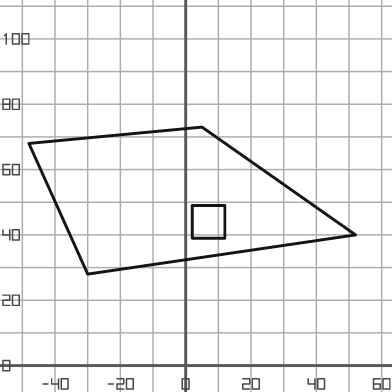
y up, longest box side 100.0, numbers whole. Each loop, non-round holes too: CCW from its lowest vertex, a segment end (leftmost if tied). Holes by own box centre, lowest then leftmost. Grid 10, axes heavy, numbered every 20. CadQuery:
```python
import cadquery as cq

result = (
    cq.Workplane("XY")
    .moveTo(-30.0, 28.0)
    .lineTo(52.0, 40.0)
    .lineTo(5.0, 73.0)
    .lineTo(-48.0, 68.0)
    .close()
    .moveTo(2.0, 39.0)
    .lineTo(12.0, 39.0)
    .lineTo(12.0, 49.0)
    .lineTo(2.0, 49.0)
    .close()
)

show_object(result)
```